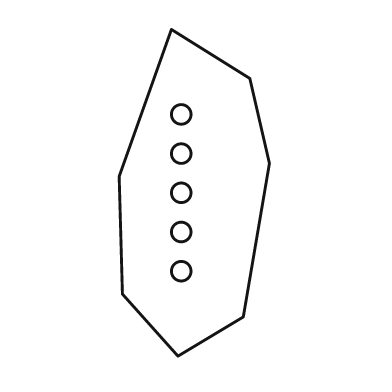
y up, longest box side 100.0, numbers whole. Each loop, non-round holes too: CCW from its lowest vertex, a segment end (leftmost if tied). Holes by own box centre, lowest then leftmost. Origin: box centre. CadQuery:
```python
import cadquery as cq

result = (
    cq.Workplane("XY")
    .moveTo(-5.0, -50.0)
    .lineTo(15.0, -38.0)
    .lineTo(23.0, 9.0)
    .lineTo(17.0, 35.0)
    .lineTo(-7.0, 50.0)
    .lineTo(-23.0, 5.0)
    .lineTo(-22.0, -31.0)
    .close()
    .moveTo(-4.0, -24.0)
    .circle(3.0)
    .moveTo(-4.0, -12.0)
    .circle(3.0)
    .moveTo(-4.0, 0.0)
    .circle(3.0)
    .moveTo(-4.0, 12.0)
    .circle(3.0)
    .moveTo(-4.0, 24.0)
    .circle(3.0)
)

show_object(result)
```